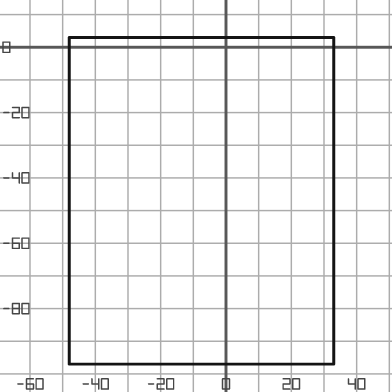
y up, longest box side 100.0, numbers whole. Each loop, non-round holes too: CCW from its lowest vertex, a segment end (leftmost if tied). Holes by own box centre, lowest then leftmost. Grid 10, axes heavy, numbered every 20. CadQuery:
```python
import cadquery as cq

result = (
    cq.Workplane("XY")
    .moveTo(-48.0, -97.0)
    .lineTo(33.0, -97.0)
    .lineTo(33.0, 3.0)
    .lineTo(-48.0, 3.0)
    .close()
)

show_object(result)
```